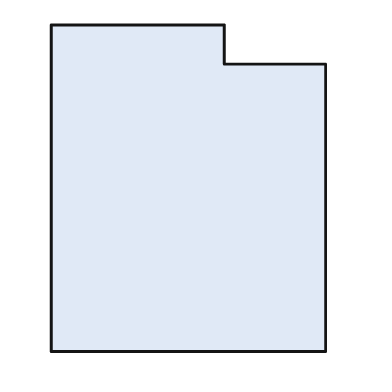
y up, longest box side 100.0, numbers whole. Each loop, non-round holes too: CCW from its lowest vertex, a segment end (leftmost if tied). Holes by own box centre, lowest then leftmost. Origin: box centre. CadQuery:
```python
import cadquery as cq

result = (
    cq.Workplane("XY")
    .moveTo(-42.0, -50.0)
    .lineTo(42.0, -50.0)
    .lineTo(42.0, 38.0)
    .lineTo(11.0, 38.0)
    .lineTo(11.0, 50.0)
    .lineTo(-42.0, 50.0)
    .close()
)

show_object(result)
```